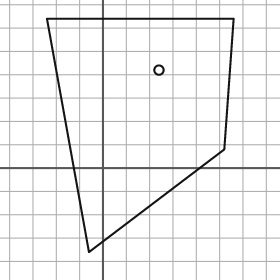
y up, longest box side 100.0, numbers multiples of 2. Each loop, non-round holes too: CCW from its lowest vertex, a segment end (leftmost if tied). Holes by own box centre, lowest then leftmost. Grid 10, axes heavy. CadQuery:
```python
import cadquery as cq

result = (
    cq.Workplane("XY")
    .moveTo(-6.0, -36.0)
    .lineTo(52.0, 8.0)
    .lineTo(56.0, 64.0)
    .lineTo(-24.0, 64.0)
    .close()
    .moveTo(24.0, 42.0)
    .circle(2.0)
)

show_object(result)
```